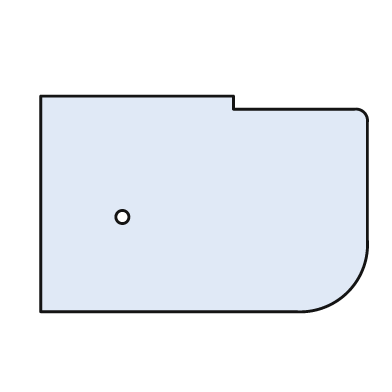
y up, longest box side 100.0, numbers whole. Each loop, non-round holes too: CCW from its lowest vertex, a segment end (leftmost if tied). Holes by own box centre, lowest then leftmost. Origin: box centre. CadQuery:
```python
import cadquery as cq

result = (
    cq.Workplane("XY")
    .moveTo(-50.0, -33.0)
    .lineTo(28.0, -33.0)
    .threePointArc((44.0, -27.0), (50.0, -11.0))
    .lineTo(50.0, 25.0)
    .threePointArc((49.0, 28.0), (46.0, 29.0))
    .lineTo(9.0, 29.0)
    .lineTo(9.0, 33.0)
    .lineTo(-50.0, 33.0)
    .close()
    .moveTo(-25.0, -4.0)
    .circle(2.0)
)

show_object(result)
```